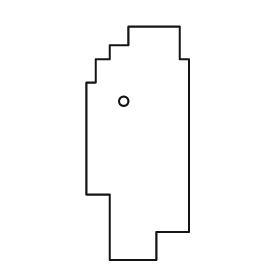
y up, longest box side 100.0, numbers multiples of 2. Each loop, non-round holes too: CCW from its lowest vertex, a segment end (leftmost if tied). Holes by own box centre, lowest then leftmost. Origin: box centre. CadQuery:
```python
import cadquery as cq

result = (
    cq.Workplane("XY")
    .moveTo(-12.0, -50.0)
    .lineTo(8.0, -50.0)
    .lineTo(8.0, -38.0)
    .lineTo(22.0, -38.0)
    .lineTo(22.0, 36.0)
    .lineTo(18.0, 36.0)
    .lineTo(18.0, 50.0)
    .lineTo(-4.0, 50.0)
    .lineTo(-4.0, 42.0)
    .lineTo(-12.0, 42.0)
    .lineTo(-12.0, 36.0)
    .lineTo(-18.0, 36.0)
    .lineTo(-18.0, 26.0)
    .lineTo(-22.0, 26.0)
    .lineTo(-22.0, -22.0)
    .lineTo(-12.0, -22.0)
    .close()
    .moveTo(-6.0, 18.0)
    .circle(2.0)
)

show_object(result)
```